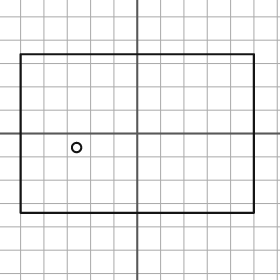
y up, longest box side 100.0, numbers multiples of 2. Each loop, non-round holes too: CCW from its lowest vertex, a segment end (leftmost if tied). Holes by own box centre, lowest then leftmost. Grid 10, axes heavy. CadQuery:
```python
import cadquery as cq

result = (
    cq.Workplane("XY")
    .moveTo(-50.0, -34.0)
    .lineTo(50.0, -34.0)
    .lineTo(50.0, 34.0)
    .lineTo(-50.0, 34.0)
    .close()
    .moveTo(-26.0, -6.0)
    .circle(2.0)
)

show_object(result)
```